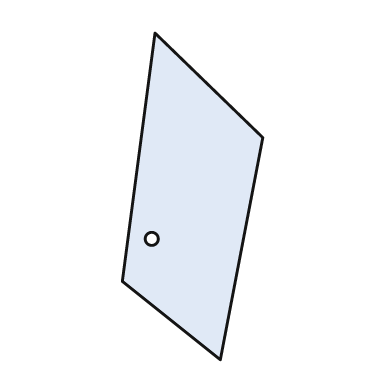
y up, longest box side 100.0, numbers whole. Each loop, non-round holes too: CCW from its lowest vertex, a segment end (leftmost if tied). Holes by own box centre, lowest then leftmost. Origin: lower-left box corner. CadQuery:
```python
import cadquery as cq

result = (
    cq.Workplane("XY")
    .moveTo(30.0, 0.0)
    .lineTo(43.0, 68.0)
    .lineTo(10.0, 100.0)
    .lineTo(0.0, 24.0)
    .close()
    .moveTo(9.0, 37.0)
    .circle(2.0)
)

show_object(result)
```